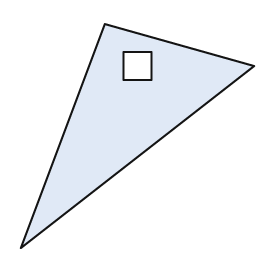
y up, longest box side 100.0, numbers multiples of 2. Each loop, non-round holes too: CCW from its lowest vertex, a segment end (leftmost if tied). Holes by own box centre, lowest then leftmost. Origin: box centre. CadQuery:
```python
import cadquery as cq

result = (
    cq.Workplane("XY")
    .moveTo(-50.0, -48.0)
    .lineTo(50.0, 30.0)
    .lineTo(-14.0, 48.0)
    .close()
    .moveTo(-6.0, 24.0)
    .lineTo(6.0, 24.0)
    .lineTo(6.0, 36.0)
    .lineTo(-6.0, 36.0)
    .close()
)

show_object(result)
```